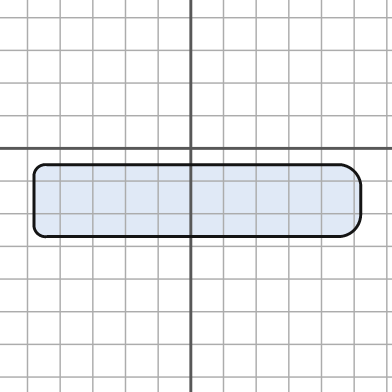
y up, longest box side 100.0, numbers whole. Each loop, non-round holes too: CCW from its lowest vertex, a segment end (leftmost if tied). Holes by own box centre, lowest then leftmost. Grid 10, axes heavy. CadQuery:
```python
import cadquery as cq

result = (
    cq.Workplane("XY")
    .moveTo(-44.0, -27.0)
    .lineTo(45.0, -27.0)
    .threePointArc((50.0, -25.0), (52.0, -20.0))
    .lineTo(52.0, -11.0)
    .threePointArc((50.0, -7.0), (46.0, -5.0))
    .lineTo(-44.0, -5.0)
    .threePointArc((-47.0, -6.0), (-48.0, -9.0))
    .lineTo(-48.0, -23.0)
    .threePointArc((-47.0, -26.0), (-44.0, -27.0))
    .close()
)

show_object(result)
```